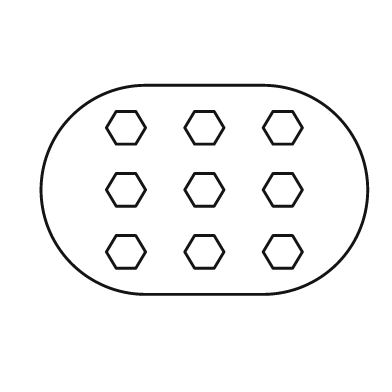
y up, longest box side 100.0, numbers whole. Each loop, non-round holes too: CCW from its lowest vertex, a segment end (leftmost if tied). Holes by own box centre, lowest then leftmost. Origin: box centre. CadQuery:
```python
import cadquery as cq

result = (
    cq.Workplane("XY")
    .moveTo(-18.0, -32.0)
    .lineTo(18.0, -32.0)
    .threePointArc((50.0, 0.0), (18.0, 32.0))
    .lineTo(-18.0, 32.0)
    .threePointArc((-50.0, 0.0), (-18.0, -32.0))
    .close()
    .moveTo(-27.0, -24.0)
    .lineTo(-21.0, -24.0)
    .lineTo(-18.0, -19.0)
    .lineTo(-21.0, -14.0)
    .lineTo(-27.0, -14.0)
    .lineTo(-30.0, -19.0)
    .close()
    .moveTo(-3.0, -24.0)
    .lineTo(3.0, -24.0)
    .lineTo(6.0, -19.0)
    .lineTo(3.0, -14.0)
    .lineTo(-3.0, -14.0)
    .lineTo(-6.0, -19.0)
    .close()
    .moveTo(21.0, -24.0)
    .lineTo(27.0, -24.0)
    .lineTo(30.0, -19.0)
    .lineTo(27.0, -14.0)
    .lineTo(21.0, -14.0)
    .lineTo(18.0, -19.0)
    .close()
    .moveTo(-27.0, -5.0)
    .lineTo(-21.0, -5.0)
    .lineTo(-18.0, 0.0)
    .lineTo(-21.0, 5.0)
    .lineTo(-27.0, 5.0)
    .lineTo(-30.0, 0.0)
    .close()
    .moveTo(-3.0, -5.0)
    .lineTo(3.0, -5.0)
    .lineTo(6.0, 0.0)
    .lineTo(3.0, 5.0)
    .lineTo(-3.0, 5.0)
    .lineTo(-6.0, 0.0)
    .close()
    .moveTo(21.0, -5.0)
    .lineTo(27.0, -5.0)
    .lineTo(30.0, 0.0)
    .lineTo(27.0, 5.0)
    .lineTo(21.0, 5.0)
    .lineTo(18.0, 0.0)
    .close()
    .moveTo(-27.0, 14.0)
    .lineTo(-21.0, 14.0)
    .lineTo(-18.0, 19.0)
    .lineTo(-21.0, 24.0)
    .lineTo(-27.0, 24.0)
    .lineTo(-30.0, 19.0)
    .close()
    .moveTo(-3.0, 14.0)
    .lineTo(3.0, 14.0)
    .lineTo(6.0, 19.0)
    .lineTo(3.0, 24.0)
    .lineTo(-3.0, 24.0)
    .lineTo(-6.0, 19.0)
    .close()
    .moveTo(21.0, 14.0)
    .lineTo(27.0, 14.0)
    .lineTo(30.0, 19.0)
    .lineTo(27.0, 24.0)
    .lineTo(21.0, 24.0)
    .lineTo(18.0, 19.0)
    .close()
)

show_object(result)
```